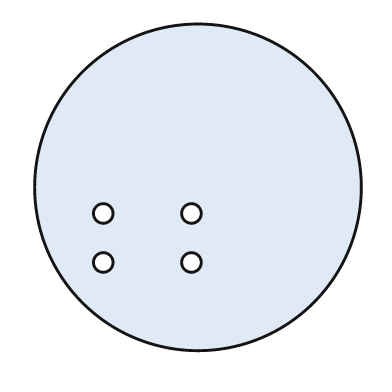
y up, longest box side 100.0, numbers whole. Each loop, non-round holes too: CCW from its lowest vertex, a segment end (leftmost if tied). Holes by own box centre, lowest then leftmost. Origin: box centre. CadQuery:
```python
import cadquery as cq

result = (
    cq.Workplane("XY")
    .moveTo(0.0, 0.0)
    .circle(50.0)
    .moveTo(-29.0, -23.0)
    .circle(3.0)
    .moveTo(-2.0, -23.0)
    .circle(3.0)
    .moveTo(-29.0, -8.0)
    .circle(3.0)
    .moveTo(-2.0, -8.0)
    .circle(3.0)
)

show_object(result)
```